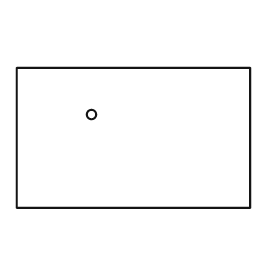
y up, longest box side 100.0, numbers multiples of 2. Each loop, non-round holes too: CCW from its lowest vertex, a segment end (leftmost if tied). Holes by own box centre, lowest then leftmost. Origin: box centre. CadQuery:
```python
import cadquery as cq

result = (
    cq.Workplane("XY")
    .moveTo(-50.0, -30.0)
    .lineTo(50.0, -30.0)
    .lineTo(50.0, 30.0)
    .lineTo(-50.0, 30.0)
    .close()
    .moveTo(-18.0, 10.0)
    .circle(2.0)
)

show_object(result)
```